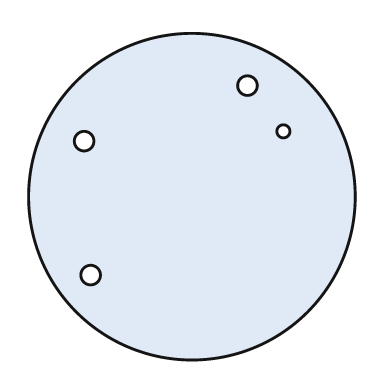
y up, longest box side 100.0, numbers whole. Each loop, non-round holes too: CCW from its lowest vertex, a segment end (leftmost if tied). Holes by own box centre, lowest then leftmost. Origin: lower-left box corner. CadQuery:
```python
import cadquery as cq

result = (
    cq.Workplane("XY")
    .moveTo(50.0, 50.0)
    .circle(50.0)
    .moveTo(19.0, 26.0)
    .circle(3.0)
    .moveTo(17.0, 67.0)
    .circle(3.0)
    .moveTo(78.0, 70.0)
    .circle(2.0)
    .moveTo(67.0, 84.0)
    .circle(3.0)
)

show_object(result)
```